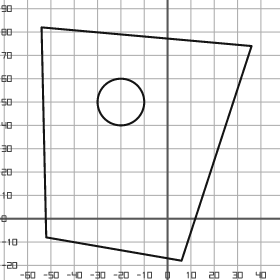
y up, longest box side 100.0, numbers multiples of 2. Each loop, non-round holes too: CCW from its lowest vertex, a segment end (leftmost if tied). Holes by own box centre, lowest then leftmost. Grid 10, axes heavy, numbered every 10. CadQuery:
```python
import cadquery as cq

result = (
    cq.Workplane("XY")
    .moveTo(6.0, -18.0)
    .lineTo(36.0, 74.0)
    .lineTo(-54.0, 82.0)
    .lineTo(-52.0, -8.0)
    .close()
    .moveTo(-20.0, 50.0)
    .circle(10.0)
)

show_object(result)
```